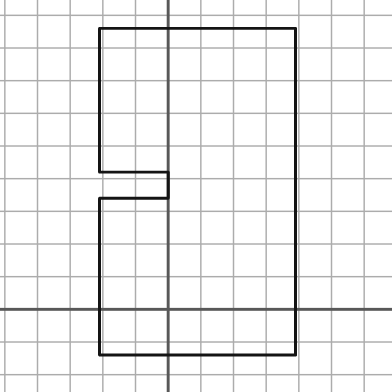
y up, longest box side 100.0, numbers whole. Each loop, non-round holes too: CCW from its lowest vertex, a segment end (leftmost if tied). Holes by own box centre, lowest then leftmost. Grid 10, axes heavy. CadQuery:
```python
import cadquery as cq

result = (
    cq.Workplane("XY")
    .moveTo(-21.0, -14.0)
    .lineTo(39.0, -14.0)
    .lineTo(39.0, 86.0)
    .lineTo(-21.0, 86.0)
    .lineTo(-21.0, 42.0)
    .lineTo(0.0, 42.0)
    .lineTo(0.0, 34.0)
    .lineTo(-21.0, 34.0)
    .close()
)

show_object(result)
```